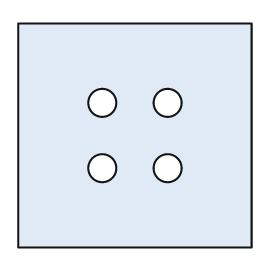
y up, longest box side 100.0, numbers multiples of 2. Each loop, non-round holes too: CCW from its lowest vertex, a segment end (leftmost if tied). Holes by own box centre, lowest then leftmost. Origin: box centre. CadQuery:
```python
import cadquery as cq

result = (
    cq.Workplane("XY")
    .moveTo(-50.0, -48.0)
    .lineTo(50.0, -48.0)
    .lineTo(50.0, 48.0)
    .lineTo(-50.0, 48.0)
    .close()
    .moveTo(-14.0, -14.0)
    .circle(6.0)
    .moveTo(14.0, -14.0)
    .circle(6.0)
    .moveTo(-14.0, 14.0)
    .circle(6.0)
    .moveTo(14.0, 14.0)
    .circle(6.0)
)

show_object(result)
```